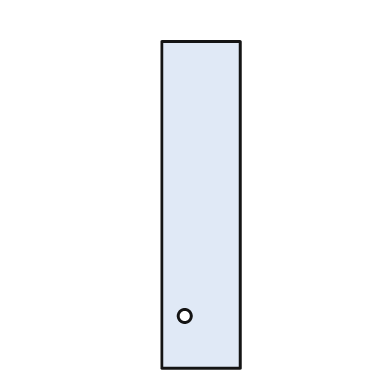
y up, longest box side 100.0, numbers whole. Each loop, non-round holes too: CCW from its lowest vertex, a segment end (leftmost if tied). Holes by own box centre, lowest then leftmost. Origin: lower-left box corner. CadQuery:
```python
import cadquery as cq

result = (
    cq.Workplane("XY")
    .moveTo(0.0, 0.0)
    .lineTo(24.0, 0.0)
    .lineTo(24.0, 100.0)
    .lineTo(0.0, 100.0)
    .close()
    .moveTo(7.0, 16.0)
    .circle(2.0)
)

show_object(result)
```